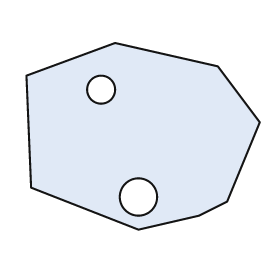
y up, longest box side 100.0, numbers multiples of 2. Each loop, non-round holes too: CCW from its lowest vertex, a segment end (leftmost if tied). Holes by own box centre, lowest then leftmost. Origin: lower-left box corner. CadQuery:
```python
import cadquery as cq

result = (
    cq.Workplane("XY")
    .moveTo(48.0, 0.0)
    .lineTo(74.0, 6.0)
    .lineTo(86.0, 12.0)
    .lineTo(100.0, 46.0)
    .lineTo(82.0, 70.0)
    .lineTo(38.0, 80.0)
    .lineTo(0.0, 66.0)
    .lineTo(2.0, 18.0)
    .close()
    .moveTo(48.0, 14.0)
    .circle(8.0)
    .moveTo(32.0, 60.0)
    .circle(6.0)
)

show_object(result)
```